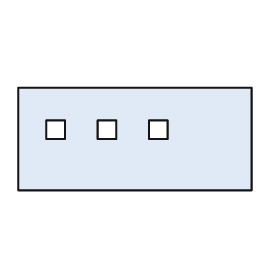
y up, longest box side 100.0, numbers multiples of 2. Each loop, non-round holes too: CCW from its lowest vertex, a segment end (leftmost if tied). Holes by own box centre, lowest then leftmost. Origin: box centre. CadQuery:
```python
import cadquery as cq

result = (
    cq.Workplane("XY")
    .moveTo(-50.0, -22.0)
    .lineTo(50.0, -22.0)
    .lineTo(50.0, 22.0)
    .lineTo(-50.0, 22.0)
    .close()
    .moveTo(-38.0, 0.0)
    .lineTo(-30.0, 0.0)
    .lineTo(-30.0, 8.0)
    .lineTo(-38.0, 8.0)
    .close()
    .moveTo(-16.0, 0.0)
    .lineTo(-8.0, 0.0)
    .lineTo(-8.0, 8.0)
    .lineTo(-16.0, 8.0)
    .close()
    .moveTo(6.0, 0.0)
    .lineTo(14.0, 0.0)
    .lineTo(14.0, 8.0)
    .lineTo(6.0, 8.0)
    .close()
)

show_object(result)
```